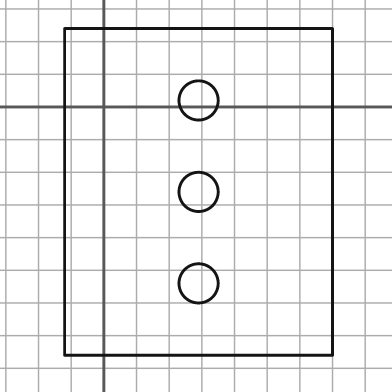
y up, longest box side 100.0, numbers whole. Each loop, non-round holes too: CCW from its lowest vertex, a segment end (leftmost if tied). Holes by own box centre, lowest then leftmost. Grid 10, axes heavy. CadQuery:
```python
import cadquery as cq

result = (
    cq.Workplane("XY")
    .moveTo(-12.0, -76.0)
    .lineTo(70.0, -76.0)
    .lineTo(70.0, 24.0)
    .lineTo(-12.0, 24.0)
    .close()
    .moveTo(29.0, -54.0)
    .circle(6.0)
    .moveTo(29.0, -26.0)
    .circle(6.0)
    .moveTo(29.0, 2.0)
    .circle(6.0)
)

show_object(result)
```